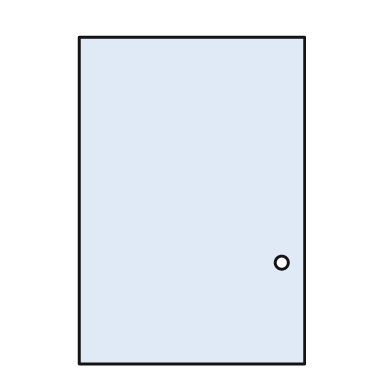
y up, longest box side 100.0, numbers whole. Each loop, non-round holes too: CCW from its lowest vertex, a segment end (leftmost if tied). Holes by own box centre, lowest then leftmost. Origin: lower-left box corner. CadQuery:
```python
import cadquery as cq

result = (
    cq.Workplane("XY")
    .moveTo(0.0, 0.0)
    .lineTo(69.0, 0.0)
    .lineTo(69.0, 100.0)
    .lineTo(0.0, 100.0)
    .close()
    .moveTo(62.0, 31.0)
    .circle(2.0)
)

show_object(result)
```